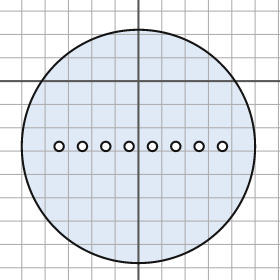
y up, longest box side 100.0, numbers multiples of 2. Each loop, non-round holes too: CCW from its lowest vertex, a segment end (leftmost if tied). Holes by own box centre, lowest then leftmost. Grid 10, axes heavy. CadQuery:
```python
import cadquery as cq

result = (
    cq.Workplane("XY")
    .moveTo(0.0, -28.0)
    .circle(50.0)
    .moveTo(-34.0, -28.0)
    .circle(2.0)
    .moveTo(-24.0, -28.0)
    .circle(2.0)
    .moveTo(-14.0, -28.0)
    .circle(2.0)
    .moveTo(-4.0, -28.0)
    .circle(2.0)
    .moveTo(6.0, -28.0)
    .circle(2.0)
    .moveTo(16.0, -28.0)
    .circle(2.0)
    .moveTo(26.0, -28.0)
    .circle(2.0)
    .moveTo(36.0, -28.0)
    .circle(2.0)
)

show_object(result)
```